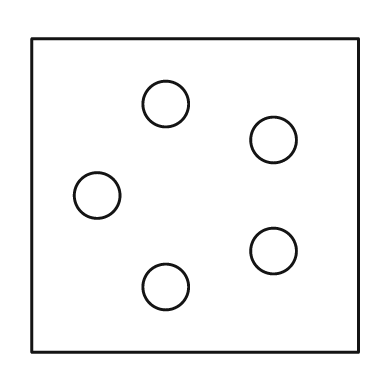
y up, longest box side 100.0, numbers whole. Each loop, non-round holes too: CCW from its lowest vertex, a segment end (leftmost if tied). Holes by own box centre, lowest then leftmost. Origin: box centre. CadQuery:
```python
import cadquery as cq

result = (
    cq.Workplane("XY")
    .moveTo(-50.0, -48.0)
    .lineTo(50.0, -48.0)
    .lineTo(50.0, 48.0)
    .lineTo(-50.0, 48.0)
    .close()
    .moveTo(-9.0, -28.0)
    .circle(7.0)
    .moveTo(24.0, -17.0)
    .circle(7.0)
    .moveTo(-30.0, 0.0)
    .circle(7.0)
    .moveTo(24.0, 17.0)
    .circle(7.0)
    .moveTo(-9.0, 28.0)
    .circle(7.0)
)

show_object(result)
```